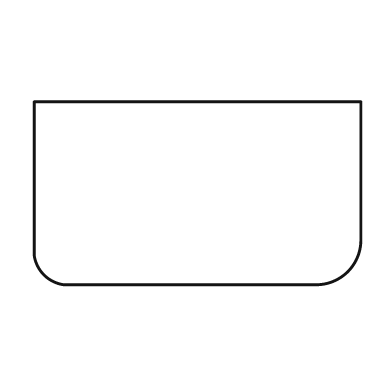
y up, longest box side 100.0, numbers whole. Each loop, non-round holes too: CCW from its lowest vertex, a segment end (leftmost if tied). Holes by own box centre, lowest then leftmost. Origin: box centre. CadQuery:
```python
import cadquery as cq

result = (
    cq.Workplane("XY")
    .moveTo(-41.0, -28.0)
    .lineTo(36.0, -28.0)
    .threePointArc((46.0, -24.0), (50.0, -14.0))
    .lineTo(50.0, 28.0)
    .lineTo(-50.0, 28.0)
    .lineTo(-50.0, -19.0)
    .threePointArc((-47.0, -25.0), (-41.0, -28.0))
    .close()
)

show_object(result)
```